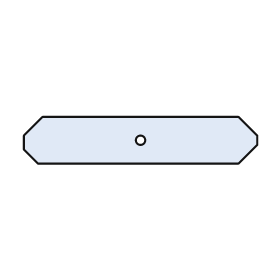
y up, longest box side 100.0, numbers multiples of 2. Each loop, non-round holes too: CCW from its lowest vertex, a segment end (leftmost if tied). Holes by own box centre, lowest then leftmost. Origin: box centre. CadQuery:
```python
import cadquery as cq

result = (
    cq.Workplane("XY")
    .moveTo(-44.0, -10.0)
    .lineTo(42.0, -10.0)
    .lineTo(50.0, -2.0)
    .lineTo(50.0, 2.0)
    .lineTo(42.0, 10.0)
    .lineTo(-42.0, 10.0)
    .lineTo(-50.0, 2.0)
    .lineTo(-50.0, -4.0)
    .close()
    .moveTo(0.0, 0.0)
    .circle(2.0)
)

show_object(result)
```